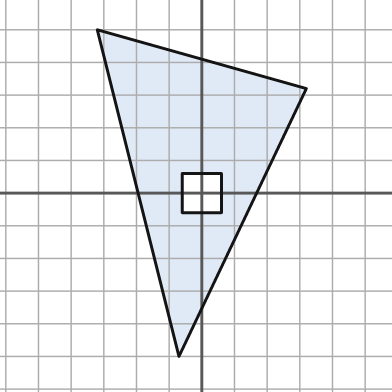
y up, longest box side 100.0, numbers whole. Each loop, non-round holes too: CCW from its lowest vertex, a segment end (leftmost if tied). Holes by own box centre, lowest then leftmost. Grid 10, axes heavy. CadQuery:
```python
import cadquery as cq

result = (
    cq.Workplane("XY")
    .moveTo(-7.0, -50.0)
    .lineTo(32.0, 32.0)
    .lineTo(-32.0, 50.0)
    .close()
    .moveTo(-6.0, -6.0)
    .lineTo(6.0, -6.0)
    .lineTo(6.0, 6.0)
    .lineTo(-6.0, 6.0)
    .close()
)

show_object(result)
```